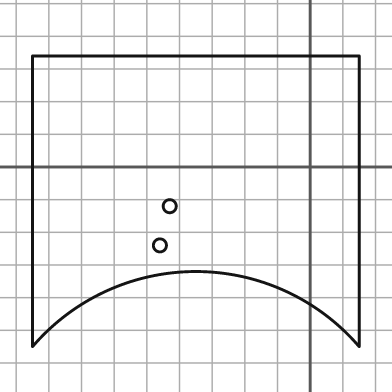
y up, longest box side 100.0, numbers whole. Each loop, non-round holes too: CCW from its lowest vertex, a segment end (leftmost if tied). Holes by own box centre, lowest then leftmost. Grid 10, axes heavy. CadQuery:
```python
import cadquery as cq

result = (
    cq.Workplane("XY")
    .moveTo(-85.0, -55.0)
    .threePointArc((-35.0, -32.0), (15.0, -55.0))
    .lineTo(15.0, 34.0)
    .lineTo(-85.0, 34.0)
    .close()
    .moveTo(-46.0, -24.0)
    .circle(2.0)
    .moveTo(-43.0, -12.0)
    .circle(2.0)
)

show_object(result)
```